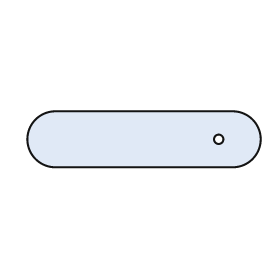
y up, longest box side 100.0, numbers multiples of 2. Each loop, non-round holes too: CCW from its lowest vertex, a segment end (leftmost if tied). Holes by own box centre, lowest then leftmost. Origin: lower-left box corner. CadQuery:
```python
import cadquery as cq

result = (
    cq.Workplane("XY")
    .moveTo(12.0, 0.0)
    .lineTo(88.0, 0.0)
    .threePointArc((100.0, 12.0), (88.0, 24.0))
    .lineTo(12.0, 24.0)
    .threePointArc((0.0, 12.0), (12.0, 0.0))
    .close()
    .moveTo(82.0, 12.0)
    .circle(2.0)
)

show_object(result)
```